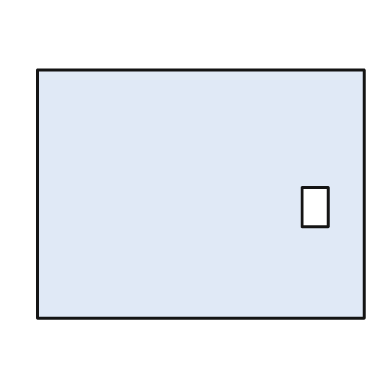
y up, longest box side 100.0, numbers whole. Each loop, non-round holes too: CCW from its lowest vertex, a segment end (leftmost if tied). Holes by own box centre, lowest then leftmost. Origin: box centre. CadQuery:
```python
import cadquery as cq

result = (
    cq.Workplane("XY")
    .moveTo(-50.0, -38.0)
    .lineTo(50.0, -38.0)
    .lineTo(50.0, 38.0)
    .lineTo(-50.0, 38.0)
    .close()
    .moveTo(31.0, -10.0)
    .lineTo(39.0, -10.0)
    .lineTo(39.0, 2.0)
    .lineTo(31.0, 2.0)
    .close()
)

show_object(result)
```